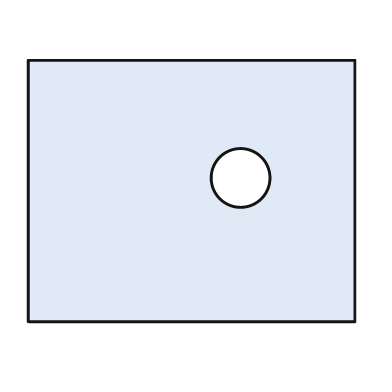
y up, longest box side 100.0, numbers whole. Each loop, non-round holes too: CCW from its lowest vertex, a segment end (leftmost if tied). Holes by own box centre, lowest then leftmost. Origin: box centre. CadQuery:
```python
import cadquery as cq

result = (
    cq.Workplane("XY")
    .moveTo(-50.0, -40.0)
    .lineTo(50.0, -40.0)
    .lineTo(50.0, 40.0)
    .lineTo(-50.0, 40.0)
    .close()
    .moveTo(15.0, 4.0)
    .circle(9.0)
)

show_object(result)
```